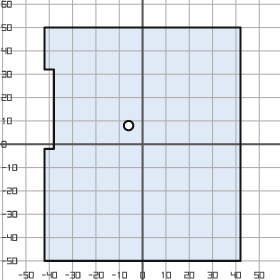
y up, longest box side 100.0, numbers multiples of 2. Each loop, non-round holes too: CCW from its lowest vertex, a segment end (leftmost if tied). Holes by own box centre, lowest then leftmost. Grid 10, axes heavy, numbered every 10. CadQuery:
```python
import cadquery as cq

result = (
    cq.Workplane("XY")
    .moveTo(-42.0, -50.0)
    .lineTo(42.0, -50.0)
    .lineTo(42.0, 50.0)
    .lineTo(-42.0, 50.0)
    .lineTo(-42.0, 32.0)
    .lineTo(-38.0, 32.0)
    .lineTo(-38.0, -2.0)
    .lineTo(-42.0, -2.0)
    .close()
    .moveTo(-6.0, 8.0)
    .circle(2.0)
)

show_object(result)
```